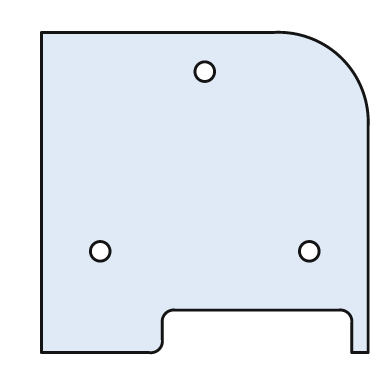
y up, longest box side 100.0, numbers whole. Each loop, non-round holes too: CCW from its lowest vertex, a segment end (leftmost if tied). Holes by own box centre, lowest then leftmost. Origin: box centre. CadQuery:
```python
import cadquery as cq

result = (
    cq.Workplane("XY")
    .moveTo(-50.0, -49.0)
    .lineTo(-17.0, -49.0)
    .threePointArc((-14.0, -48.0), (-13.0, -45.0))
    .lineTo(-13.0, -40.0)
    .threePointArc((-12.0, -37.0), (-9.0, -36.0))
    .lineTo(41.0, -36.0)
    .threePointArc((44.0, -37.0), (45.0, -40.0))
    .lineTo(45.0, -49.0)
    .lineTo(50.0, -49.0)
    .lineTo(50.0, 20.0)
    .threePointArc((42.0, 41.0), (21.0, 49.0))
    .lineTo(-50.0, 49.0)
    .close()
    .moveTo(-32.0, -18.0)
    .circle(3.0)
    .moveTo(32.0, -18.0)
    .circle(3.0)
    .moveTo(0.0, 37.0)
    .circle(3.0)
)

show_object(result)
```